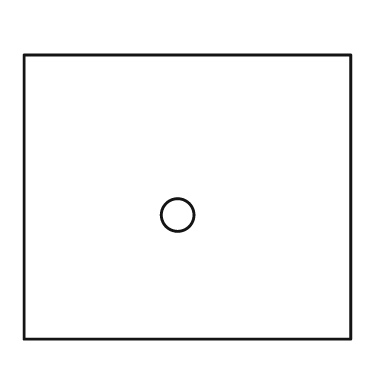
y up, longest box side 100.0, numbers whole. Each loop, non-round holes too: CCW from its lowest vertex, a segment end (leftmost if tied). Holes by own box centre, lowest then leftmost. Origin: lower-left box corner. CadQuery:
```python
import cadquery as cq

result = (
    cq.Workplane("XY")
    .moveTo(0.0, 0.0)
    .lineTo(100.0, 0.0)
    .lineTo(100.0, 87.0)
    .lineTo(0.0, 87.0)
    .close()
    .moveTo(47.0, 38.0)
    .circle(5.0)
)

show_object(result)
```